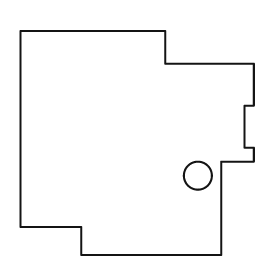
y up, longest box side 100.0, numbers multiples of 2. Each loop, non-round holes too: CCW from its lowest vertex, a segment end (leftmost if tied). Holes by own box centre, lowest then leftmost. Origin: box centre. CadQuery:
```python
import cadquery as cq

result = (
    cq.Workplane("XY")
    .moveTo(-24.0, -48.0)
    .lineTo(36.0, -48.0)
    .lineTo(36.0, -8.0)
    .lineTo(50.0, -8.0)
    .lineTo(50.0, -2.0)
    .lineTo(46.0, -2.0)
    .lineTo(46.0, 16.0)
    .lineTo(50.0, 16.0)
    .lineTo(50.0, 34.0)
    .lineTo(12.0, 34.0)
    .lineTo(12.0, 48.0)
    .lineTo(-50.0, 48.0)
    .lineTo(-50.0, -36.0)
    .lineTo(-24.0, -36.0)
    .close()
    .moveTo(26.0, -14.0)
    .circle(6.0)
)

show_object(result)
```